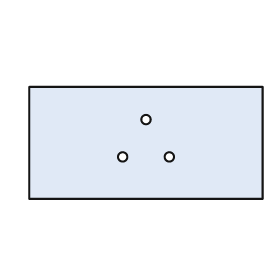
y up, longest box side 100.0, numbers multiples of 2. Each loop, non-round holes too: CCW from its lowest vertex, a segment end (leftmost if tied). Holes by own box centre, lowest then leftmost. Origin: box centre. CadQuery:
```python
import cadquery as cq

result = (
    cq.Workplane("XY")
    .moveTo(-50.0, -24.0)
    .lineTo(50.0, -24.0)
    .lineTo(50.0, 24.0)
    .lineTo(-50.0, 24.0)
    .close()
    .moveTo(-10.0, -6.0)
    .circle(2.0)
    .moveTo(10.0, -6.0)
    .circle(2.0)
    .moveTo(0.0, 10.0)
    .circle(2.0)
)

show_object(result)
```